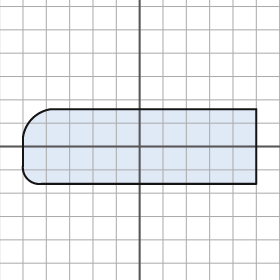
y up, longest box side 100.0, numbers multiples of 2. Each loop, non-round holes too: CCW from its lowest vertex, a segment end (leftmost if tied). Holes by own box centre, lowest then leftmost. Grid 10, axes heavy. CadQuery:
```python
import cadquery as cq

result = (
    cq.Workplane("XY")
    .moveTo(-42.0, -16.0)
    .lineTo(50.0, -16.0)
    .lineTo(50.0, 16.0)
    .lineTo(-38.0, 16.0)
    .threePointArc((-46.0, 12.0), (-50.0, 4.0))
    .lineTo(-50.0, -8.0)
    .threePointArc((-48.0, -14.0), (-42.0, -16.0))
    .close()
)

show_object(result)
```